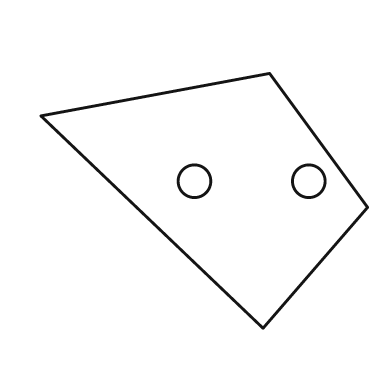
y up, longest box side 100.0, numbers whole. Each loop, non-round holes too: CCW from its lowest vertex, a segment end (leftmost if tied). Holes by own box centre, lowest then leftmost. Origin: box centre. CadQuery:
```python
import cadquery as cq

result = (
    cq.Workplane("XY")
    .moveTo(18.0, -39.0)
    .lineTo(50.0, -2.0)
    .lineTo(20.0, 39.0)
    .lineTo(-50.0, 26.0)
    .close()
    .moveTo(-3.0, 6.0)
    .circle(5.0)
    .moveTo(32.0, 6.0)
    .circle(5.0)
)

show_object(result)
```